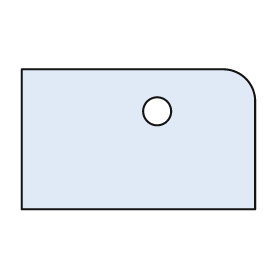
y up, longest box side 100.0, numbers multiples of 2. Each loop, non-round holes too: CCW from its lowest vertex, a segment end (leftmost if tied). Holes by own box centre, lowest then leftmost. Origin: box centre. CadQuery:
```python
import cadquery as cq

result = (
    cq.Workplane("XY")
    .moveTo(-50.0, -30.0)
    .lineTo(50.0, -30.0)
    .lineTo(50.0, 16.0)
    .threePointArc((46.0, 26.0), (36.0, 30.0))
    .lineTo(-50.0, 30.0)
    .close()
    .moveTo(8.0, 12.0)
    .circle(6.0)
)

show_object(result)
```